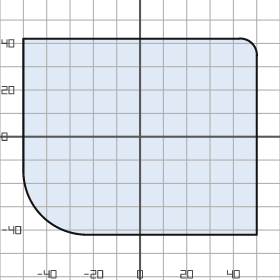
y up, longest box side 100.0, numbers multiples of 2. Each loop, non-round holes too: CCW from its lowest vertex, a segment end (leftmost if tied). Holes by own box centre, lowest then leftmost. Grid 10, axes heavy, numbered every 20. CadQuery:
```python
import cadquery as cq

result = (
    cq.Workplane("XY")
    .moveTo(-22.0, -42.0)
    .lineTo(50.0, -42.0)
    .lineTo(50.0, 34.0)
    .threePointArc((48.0, 40.0), (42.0, 42.0))
    .lineTo(-50.0, 42.0)
    .lineTo(-50.0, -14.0)
    .threePointArc((-42.0, -34.0), (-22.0, -42.0))
    .close()
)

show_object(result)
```